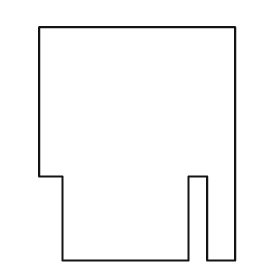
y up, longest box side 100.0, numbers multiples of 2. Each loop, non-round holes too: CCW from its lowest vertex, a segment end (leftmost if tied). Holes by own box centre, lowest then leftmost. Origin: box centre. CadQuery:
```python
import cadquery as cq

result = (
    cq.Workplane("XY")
    .moveTo(-32.0, -50.0)
    .lineTo(22.0, -50.0)
    .lineTo(22.0, -14.0)
    .lineTo(30.0, -14.0)
    .lineTo(30.0, -50.0)
    .lineTo(42.0, -50.0)
    .lineTo(42.0, 50.0)
    .lineTo(-42.0, 50.0)
    .lineTo(-42.0, -14.0)
    .lineTo(-32.0, -14.0)
    .close()
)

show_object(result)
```